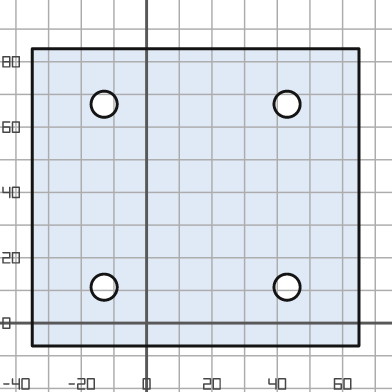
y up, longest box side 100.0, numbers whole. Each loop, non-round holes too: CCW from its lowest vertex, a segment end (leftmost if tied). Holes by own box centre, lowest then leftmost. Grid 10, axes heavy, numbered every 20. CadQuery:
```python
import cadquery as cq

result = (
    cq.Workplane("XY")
    .moveTo(-35.0, -7.0)
    .lineTo(65.0, -7.0)
    .lineTo(65.0, 84.0)
    .lineTo(-35.0, 84.0)
    .close()
    .moveTo(-13.0, 11.0)
    .circle(4.0)
    .moveTo(43.0, 11.0)
    .circle(4.0)
    .moveTo(-13.0, 67.0)
    .circle(4.0)
    .moveTo(43.0, 67.0)
    .circle(4.0)
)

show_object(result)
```